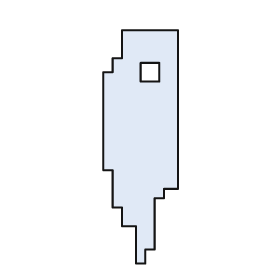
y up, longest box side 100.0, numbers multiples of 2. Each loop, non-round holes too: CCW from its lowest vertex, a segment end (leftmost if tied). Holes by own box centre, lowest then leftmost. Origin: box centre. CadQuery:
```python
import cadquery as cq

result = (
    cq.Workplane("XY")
    .moveTo(-2.0, -50.0)
    .lineTo(2.0, -50.0)
    .lineTo(2.0, -44.0)
    .lineTo(6.0, -44.0)
    .lineTo(6.0, -22.0)
    .lineTo(10.0, -22.0)
    .lineTo(10.0, -18.0)
    .lineTo(16.0, -18.0)
    .lineTo(16.0, 50.0)
    .lineTo(-8.0, 50.0)
    .lineTo(-8.0, 38.0)
    .lineTo(-12.0, 38.0)
    .lineTo(-12.0, 32.0)
    .lineTo(-16.0, 32.0)
    .lineTo(-16.0, -10.0)
    .lineTo(-12.0, -10.0)
    .lineTo(-12.0, -26.0)
    .lineTo(-8.0, -26.0)
    .lineTo(-8.0, -34.0)
    .lineTo(-2.0, -34.0)
    .close()
    .moveTo(0.0, 28.0)
    .lineTo(8.0, 28.0)
    .lineTo(8.0, 36.0)
    .lineTo(0.0, 36.0)
    .close()
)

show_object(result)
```